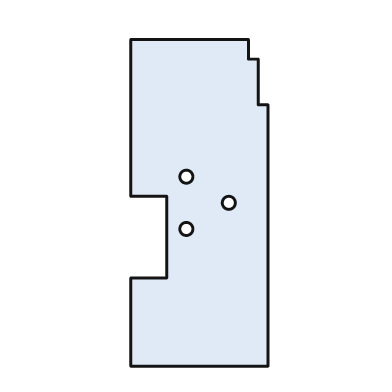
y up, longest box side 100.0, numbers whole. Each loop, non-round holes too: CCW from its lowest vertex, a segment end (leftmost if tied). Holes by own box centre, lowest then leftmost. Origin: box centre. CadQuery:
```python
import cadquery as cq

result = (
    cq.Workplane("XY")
    .moveTo(-21.0, -50.0)
    .lineTo(21.0, -50.0)
    .lineTo(21.0, 30.0)
    .lineTo(18.0, 30.0)
    .lineTo(18.0, 44.0)
    .lineTo(15.0, 44.0)
    .lineTo(15.0, 50.0)
    .lineTo(-21.0, 50.0)
    .lineTo(-21.0, 2.0)
    .lineTo(-10.0, 2.0)
    .lineTo(-10.0, -23.0)
    .lineTo(-21.0, -23.0)
    .close()
    .moveTo(-4.0, -8.0)
    .circle(2.0)
    .moveTo(9.0, 0.0)
    .circle(2.0)
    .moveTo(-4.0, 8.0)
    .circle(2.0)
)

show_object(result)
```